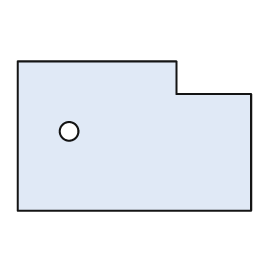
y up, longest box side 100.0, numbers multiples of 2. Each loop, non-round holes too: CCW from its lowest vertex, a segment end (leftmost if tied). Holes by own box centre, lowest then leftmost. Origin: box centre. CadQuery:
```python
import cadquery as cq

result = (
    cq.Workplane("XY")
    .moveTo(-50.0, -32.0)
    .lineTo(50.0, -32.0)
    .lineTo(50.0, 18.0)
    .lineTo(18.0, 18.0)
    .lineTo(18.0, 32.0)
    .lineTo(-50.0, 32.0)
    .close()
    .moveTo(-28.0, 2.0)
    .circle(4.0)
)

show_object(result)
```